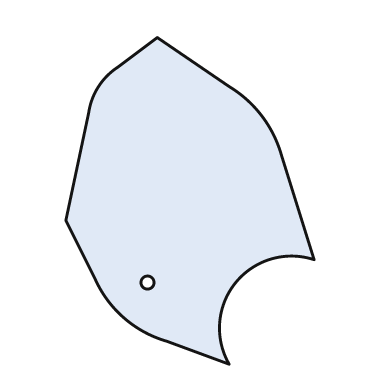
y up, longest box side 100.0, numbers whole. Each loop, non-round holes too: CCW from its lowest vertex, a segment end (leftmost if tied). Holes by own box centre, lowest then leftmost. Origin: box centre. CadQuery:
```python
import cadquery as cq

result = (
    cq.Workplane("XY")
    .moveTo(12.0, -50.0)
    .threePointArc((14.0, -25.0), (38.0, -18.0))
    .lineTo(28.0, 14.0)
    .threePointArc((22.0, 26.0), (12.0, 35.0))
    .lineTo(-10.0, 50.0)
    .lineTo(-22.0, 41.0)
    .threePointArc((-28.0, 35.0), (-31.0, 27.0))
    .lineTo(-38.0, -6.0)
    .lineTo(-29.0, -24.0)
    .threePointArc((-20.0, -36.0), (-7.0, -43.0))
    .close()
    .moveTo(-13.0, -25.0)
    .circle(2.0)
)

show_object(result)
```